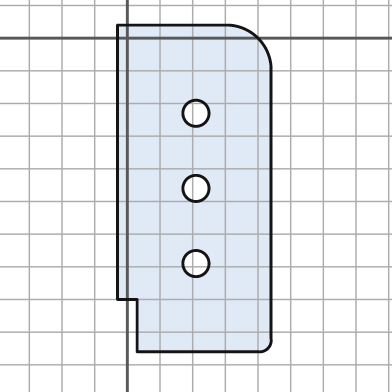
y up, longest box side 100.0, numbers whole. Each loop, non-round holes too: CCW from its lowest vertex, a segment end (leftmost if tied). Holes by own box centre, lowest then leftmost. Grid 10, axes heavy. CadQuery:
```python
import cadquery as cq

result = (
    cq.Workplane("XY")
    .moveTo(3.0, -96.0)
    .lineTo(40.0, -96.0)
    .threePointArc((43.0, -95.0), (44.0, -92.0))
    .lineTo(44.0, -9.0)
    .threePointArc((40.0, 0.0), (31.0, 4.0))
    .lineTo(-3.0, 4.0)
    .lineTo(-3.0, -80.0)
    .lineTo(3.0, -80.0)
    .close()
    .moveTo(21.0, -69.0)
    .circle(4.0)
    .moveTo(21.0, -46.0)
    .circle(4.0)
    .moveTo(21.0, -23.0)
    .circle(4.0)
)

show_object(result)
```